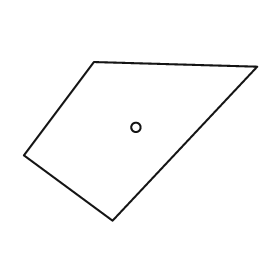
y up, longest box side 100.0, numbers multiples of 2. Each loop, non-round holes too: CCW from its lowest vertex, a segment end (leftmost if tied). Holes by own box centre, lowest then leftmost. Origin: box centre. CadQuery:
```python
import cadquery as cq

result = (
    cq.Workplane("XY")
    .moveTo(-12.0, -34.0)
    .lineTo(50.0, 32.0)
    .lineTo(-20.0, 34.0)
    .lineTo(-50.0, -6.0)
    .close()
    .moveTo(-2.0, 6.0)
    .circle(2.0)
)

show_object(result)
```